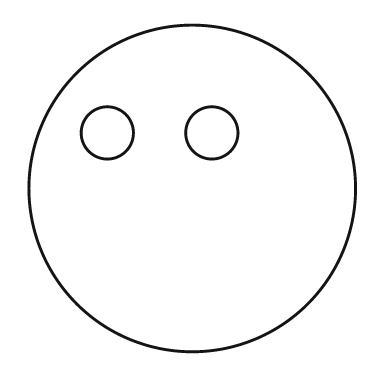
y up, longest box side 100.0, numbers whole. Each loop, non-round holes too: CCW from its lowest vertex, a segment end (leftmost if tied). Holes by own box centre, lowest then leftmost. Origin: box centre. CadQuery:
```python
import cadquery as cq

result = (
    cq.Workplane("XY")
    .moveTo(0.0, 0.0)
    .circle(50.0)
    .moveTo(-26.0, 17.0)
    .circle(8.0)
    .moveTo(6.0, 17.0)
    .circle(8.0)
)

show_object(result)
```